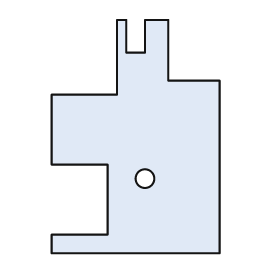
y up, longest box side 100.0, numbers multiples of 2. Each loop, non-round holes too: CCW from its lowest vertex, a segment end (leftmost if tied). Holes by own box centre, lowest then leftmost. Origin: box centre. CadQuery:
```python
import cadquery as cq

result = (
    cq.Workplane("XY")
    .moveTo(-36.0, -50.0)
    .lineTo(36.0, -50.0)
    .lineTo(36.0, 24.0)
    .lineTo(14.0, 24.0)
    .lineTo(14.0, 50.0)
    .lineTo(4.0, 50.0)
    .lineTo(4.0, 36.0)
    .lineTo(-4.0, 36.0)
    .lineTo(-4.0, 50.0)
    .lineTo(-8.0, 50.0)
    .lineTo(-8.0, 18.0)
    .lineTo(-36.0, 18.0)
    .lineTo(-36.0, -12.0)
    .lineTo(-12.0, -12.0)
    .lineTo(-12.0, -42.0)
    .lineTo(-36.0, -42.0)
    .close()
    .moveTo(4.0, -18.0)
    .circle(4.0)
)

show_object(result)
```